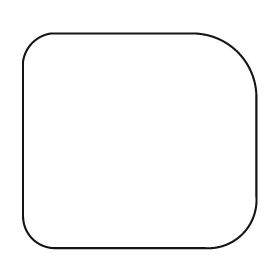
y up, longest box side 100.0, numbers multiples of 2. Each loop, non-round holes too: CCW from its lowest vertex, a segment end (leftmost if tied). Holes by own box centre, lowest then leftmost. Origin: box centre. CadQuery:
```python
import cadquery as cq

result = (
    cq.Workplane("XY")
    .moveTo(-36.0, -46.0)
    .lineTo(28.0, -46.0)
    .threePointArc((44.0, -40.0), (50.0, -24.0))
    .lineTo(50.0, 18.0)
    .threePointArc((42.0, 38.0), (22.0, 46.0))
    .lineTo(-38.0, 46.0)
    .threePointArc((-46.0, 42.0), (-50.0, 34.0))
    .lineTo(-50.0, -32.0)
    .threePointArc((-46.0, -42.0), (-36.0, -46.0))
    .close()
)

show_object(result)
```